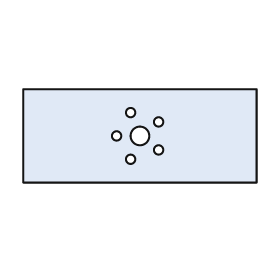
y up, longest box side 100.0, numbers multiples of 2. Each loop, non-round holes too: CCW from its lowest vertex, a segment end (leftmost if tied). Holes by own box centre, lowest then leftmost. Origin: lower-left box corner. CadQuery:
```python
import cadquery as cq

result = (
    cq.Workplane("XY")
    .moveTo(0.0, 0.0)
    .lineTo(100.0, 0.0)
    .lineTo(100.0, 40.0)
    .lineTo(0.0, 40.0)
    .close()
    .moveTo(46.0, 10.0)
    .circle(2.0)
    .moveTo(58.0, 14.0)
    .circle(2.0)
    .moveTo(40.0, 20.0)
    .circle(2.0)
    .moveTo(50.0, 20.0)
    .circle(4.0)
    .moveTo(58.0, 26.0)
    .circle(2.0)
    .moveTo(46.0, 30.0)
    .circle(2.0)
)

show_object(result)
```